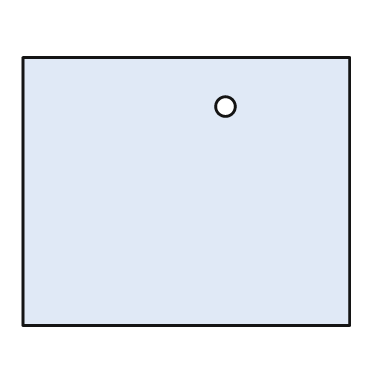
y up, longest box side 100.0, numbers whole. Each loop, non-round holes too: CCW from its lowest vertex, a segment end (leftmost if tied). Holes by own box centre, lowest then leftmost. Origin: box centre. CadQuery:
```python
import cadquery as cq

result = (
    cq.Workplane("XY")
    .moveTo(-50.0, -41.0)
    .lineTo(50.0, -41.0)
    .lineTo(50.0, 41.0)
    .lineTo(-50.0, 41.0)
    .close()
    .moveTo(12.0, 26.0)
    .circle(3.0)
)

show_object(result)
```